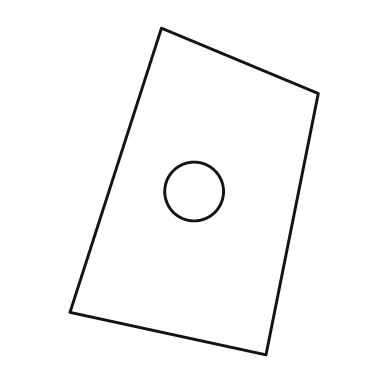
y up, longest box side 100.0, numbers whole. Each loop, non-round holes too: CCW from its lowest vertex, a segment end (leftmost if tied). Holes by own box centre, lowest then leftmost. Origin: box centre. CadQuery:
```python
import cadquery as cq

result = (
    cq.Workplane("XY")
    .moveTo(22.0, -50.0)
    .lineTo(38.0, 30.0)
    .lineTo(-10.0, 50.0)
    .lineTo(-38.0, -37.0)
    .close()
    .moveTo(0.0, 0.0)
    .circle(9.0)
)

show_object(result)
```